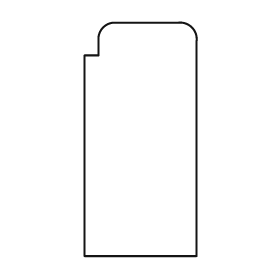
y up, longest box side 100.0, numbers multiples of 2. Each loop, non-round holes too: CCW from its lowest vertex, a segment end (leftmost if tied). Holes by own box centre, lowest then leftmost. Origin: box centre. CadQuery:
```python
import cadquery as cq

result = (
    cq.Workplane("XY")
    .moveTo(-24.0, -50.0)
    .lineTo(24.0, -50.0)
    .lineTo(24.0, 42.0)
    .threePointArc((22.0, 48.0), (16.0, 50.0))
    .lineTo(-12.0, 50.0)
    .threePointArc((-16.0, 48.0), (-18.0, 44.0))
    .lineTo(-18.0, 36.0)
    .lineTo(-24.0, 36.0)
    .close()
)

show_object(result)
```